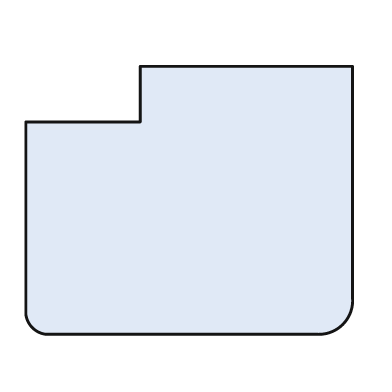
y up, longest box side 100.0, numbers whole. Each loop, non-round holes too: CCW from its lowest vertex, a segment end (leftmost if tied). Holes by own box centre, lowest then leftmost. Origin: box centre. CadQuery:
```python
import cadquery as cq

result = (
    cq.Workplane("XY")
    .moveTo(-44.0, -41.0)
    .lineTo(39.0, -41.0)
    .threePointArc((47.0, -38.0), (50.0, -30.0))
    .lineTo(50.0, 41.0)
    .lineTo(-15.0, 41.0)
    .lineTo(-15.0, 24.0)
    .lineTo(-50.0, 24.0)
    .lineTo(-50.0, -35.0)
    .threePointArc((-48.0, -39.0), (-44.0, -41.0))
    .close()
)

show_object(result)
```